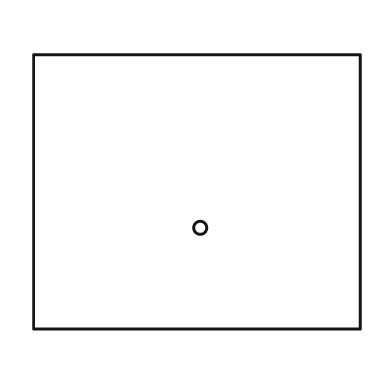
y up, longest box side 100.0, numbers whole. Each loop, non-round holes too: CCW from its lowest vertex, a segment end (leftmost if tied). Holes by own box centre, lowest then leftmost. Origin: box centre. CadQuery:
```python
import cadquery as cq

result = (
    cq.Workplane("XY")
    .moveTo(-50.0, -42.0)
    .lineTo(50.0, -42.0)
    .lineTo(50.0, 42.0)
    .lineTo(-50.0, 42.0)
    .close()
    .moveTo(1.0, -11.0)
    .circle(2.0)
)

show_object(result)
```